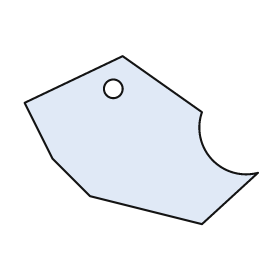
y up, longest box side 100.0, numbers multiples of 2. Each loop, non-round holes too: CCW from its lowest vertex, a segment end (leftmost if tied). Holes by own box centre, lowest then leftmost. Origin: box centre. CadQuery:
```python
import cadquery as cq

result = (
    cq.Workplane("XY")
    .moveTo(26.0, -36.0)
    .lineTo(50.0, -14.0)
    .threePointArc((30.0, -8.0), (26.0, 12.0))
    .lineTo(-8.0, 36.0)
    .lineTo(-50.0, 16.0)
    .lineTo(-38.0, -8.0)
    .lineTo(-22.0, -24.0)
    .close()
    .moveTo(-12.0, 22.0)
    .circle(4.0)
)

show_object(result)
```